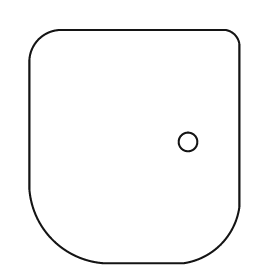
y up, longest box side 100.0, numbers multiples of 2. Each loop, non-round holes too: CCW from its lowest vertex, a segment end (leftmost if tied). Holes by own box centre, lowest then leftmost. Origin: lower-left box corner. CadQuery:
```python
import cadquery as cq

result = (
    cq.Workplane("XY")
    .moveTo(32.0, 0.0)
    .lineTo(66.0, 0.0)
    .threePointArc((82.0, 8.0), (90.0, 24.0))
    .lineTo(90.0, 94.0)
    .threePointArc((88.0, 98.0), (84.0, 100.0))
    .lineTo(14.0, 100.0)
    .threePointArc((4.0, 96.0), (0.0, 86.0))
    .lineTo(0.0, 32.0)
    .threePointArc((10.0, 10.0), (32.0, 0.0))
    .close()
    .moveTo(68.0, 52.0)
    .circle(4.0)
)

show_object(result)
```